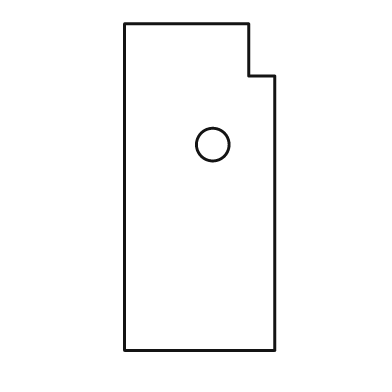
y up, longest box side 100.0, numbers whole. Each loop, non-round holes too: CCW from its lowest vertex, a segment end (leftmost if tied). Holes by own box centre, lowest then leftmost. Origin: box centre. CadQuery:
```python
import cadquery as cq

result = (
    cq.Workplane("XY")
    .moveTo(-23.0, -50.0)
    .lineTo(23.0, -50.0)
    .lineTo(23.0, 34.0)
    .lineTo(15.0, 34.0)
    .lineTo(15.0, 50.0)
    .lineTo(-23.0, 50.0)
    .close()
    .moveTo(4.0, 13.0)
    .circle(5.0)
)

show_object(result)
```